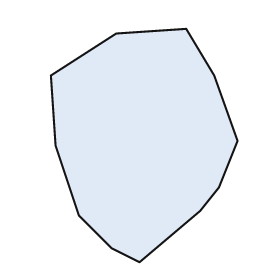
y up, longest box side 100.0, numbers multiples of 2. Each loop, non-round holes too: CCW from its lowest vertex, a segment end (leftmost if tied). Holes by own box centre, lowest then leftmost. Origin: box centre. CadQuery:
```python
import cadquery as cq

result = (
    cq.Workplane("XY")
    .moveTo(-2.0, -50.0)
    .lineTo(24.0, -28.0)
    .lineTo(32.0, -18.0)
    .lineTo(40.0, 2.0)
    .lineTo(30.0, 30.0)
    .lineTo(18.0, 50.0)
    .lineTo(-12.0, 48.0)
    .lineTo(-40.0, 30.0)
    .lineTo(-38.0, 0.0)
    .lineTo(-28.0, -30.0)
    .lineTo(-14.0, -44.0)
    .close()
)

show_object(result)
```